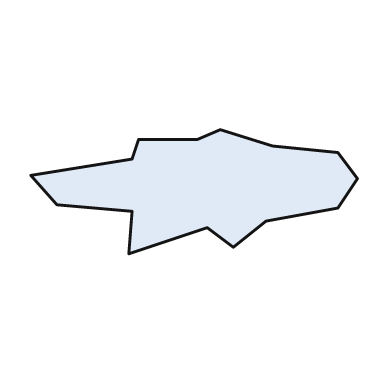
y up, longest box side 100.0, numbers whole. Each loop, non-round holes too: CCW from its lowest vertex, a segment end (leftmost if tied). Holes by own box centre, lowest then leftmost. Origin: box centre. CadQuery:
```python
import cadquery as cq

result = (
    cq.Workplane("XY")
    .moveTo(-20.0, -19.0)
    .lineTo(4.0, -11.0)
    .lineTo(12.0, -17.0)
    .lineTo(22.0, -9.0)
    .lineTo(44.0, -5.0)
    .lineTo(50.0, 4.0)
    .lineTo(44.0, 12.0)
    .lineTo(24.0, 14.0)
    .lineTo(8.0, 19.0)
    .lineTo(1.0, 16.0)
    .lineTo(-17.0, 16.0)
    .lineTo(-19.0, 10.0)
    .lineTo(-50.0, 5.0)
    .lineTo(-42.0, -4.0)
    .lineTo(-19.0, -6.0)
    .close()
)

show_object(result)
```